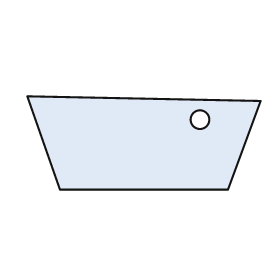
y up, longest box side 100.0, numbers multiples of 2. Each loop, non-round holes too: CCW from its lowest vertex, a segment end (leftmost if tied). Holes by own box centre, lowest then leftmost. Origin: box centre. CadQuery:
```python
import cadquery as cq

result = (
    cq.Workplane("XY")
    .moveTo(-36.0, -20.0)
    .lineTo(36.0, -20.0)
    .lineTo(50.0, 18.0)
    .lineTo(-50.0, 20.0)
    .close()
    .moveTo(24.0, 10.0)
    .circle(4.0)
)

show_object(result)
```